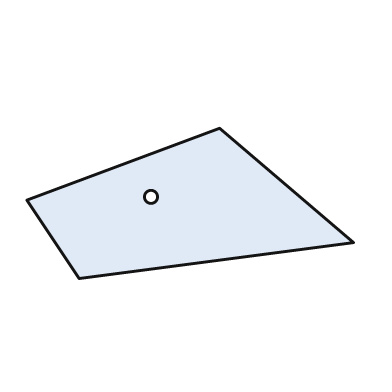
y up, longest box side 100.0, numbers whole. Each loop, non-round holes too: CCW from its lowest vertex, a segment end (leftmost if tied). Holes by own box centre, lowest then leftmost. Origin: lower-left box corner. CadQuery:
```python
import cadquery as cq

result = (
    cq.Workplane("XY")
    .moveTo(16.0, 0.0)
    .lineTo(100.0, 11.0)
    .lineTo(59.0, 46.0)
    .lineTo(0.0, 24.0)
    .close()
    .moveTo(38.0, 25.0)
    .circle(2.0)
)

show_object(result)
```